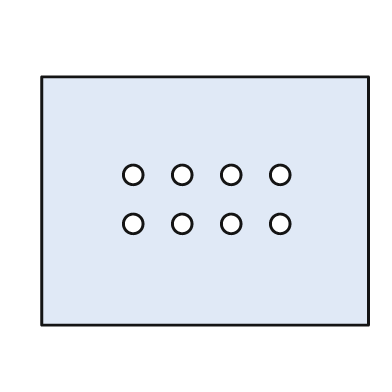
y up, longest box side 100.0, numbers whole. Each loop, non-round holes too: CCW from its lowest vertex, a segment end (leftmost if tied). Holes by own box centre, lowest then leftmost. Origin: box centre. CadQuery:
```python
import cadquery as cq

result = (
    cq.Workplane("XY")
    .moveTo(-50.0, -38.0)
    .lineTo(50.0, -38.0)
    .lineTo(50.0, 38.0)
    .lineTo(-50.0, 38.0)
    .close()
    .moveTo(-22.0, -7.0)
    .circle(3.0)
    .moveTo(-7.0, -7.0)
    .circle(3.0)
    .moveTo(8.0, -7.0)
    .circle(3.0)
    .moveTo(23.0, -7.0)
    .circle(3.0)
    .moveTo(-22.0, 8.0)
    .circle(3.0)
    .moveTo(-7.0, 8.0)
    .circle(3.0)
    .moveTo(8.0, 8.0)
    .circle(3.0)
    .moveTo(23.0, 8.0)
    .circle(3.0)
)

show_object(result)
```